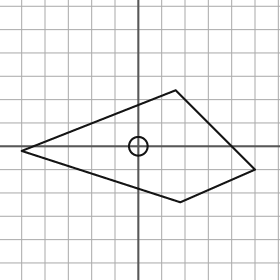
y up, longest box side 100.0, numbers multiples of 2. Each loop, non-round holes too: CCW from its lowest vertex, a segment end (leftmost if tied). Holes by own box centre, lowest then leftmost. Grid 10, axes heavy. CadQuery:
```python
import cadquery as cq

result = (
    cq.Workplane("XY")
    .moveTo(18.0, -24.0)
    .lineTo(50.0, -10.0)
    .lineTo(16.0, 24.0)
    .lineTo(-50.0, -2.0)
    .close()
    .moveTo(0.0, 0.0)
    .circle(4.0)
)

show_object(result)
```